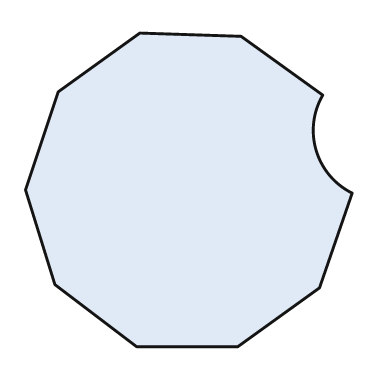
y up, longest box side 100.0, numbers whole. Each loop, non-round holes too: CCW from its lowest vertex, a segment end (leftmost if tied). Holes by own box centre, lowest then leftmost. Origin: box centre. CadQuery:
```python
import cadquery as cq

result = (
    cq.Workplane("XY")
    .moveTo(-16.0, -48.0)
    .lineTo(15.0, -48.0)
    .lineTo(40.0, -30.0)
    .lineTo(50.0, -1.0)
    .threePointArc((39.0, 12.0), (41.0, 29.0))
    .lineTo(16.0, 47.0)
    .lineTo(-15.0, 48.0)
    .lineTo(-40.0, 30.0)
    .lineTo(-50.0, 0.0)
    .lineTo(-41.0, -29.0)
    .close()
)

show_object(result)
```